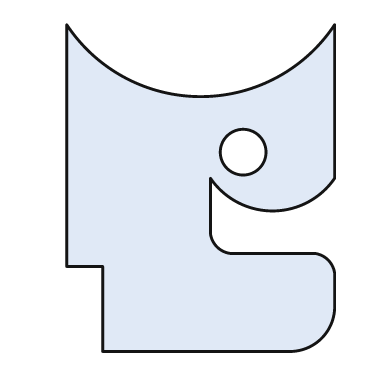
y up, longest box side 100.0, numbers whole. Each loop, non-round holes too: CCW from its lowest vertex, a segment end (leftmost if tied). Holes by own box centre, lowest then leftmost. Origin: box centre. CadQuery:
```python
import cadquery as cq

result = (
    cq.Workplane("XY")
    .moveTo(-30.0, -50.0)
    .lineTo(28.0, -50.0)
    .threePointArc((37.0, -46.0), (41.0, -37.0))
    .lineTo(41.0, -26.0)
    .threePointArc((39.0, -22.0), (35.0, -20.0))
    .lineTo(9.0, -20.0)
    .threePointArc((5.0, -18.0), (3.0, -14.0))
    .lineTo(3.0, 3.0)
    .threePointArc((22.0, -7.0), (41.0, 3.0))
    .lineTo(41.0, 50.0)
    .threePointArc((0.0, 28.0), (-41.0, 50.0))
    .lineTo(-41.0, -24.0)
    .lineTo(-30.0, -24.0)
    .close()
    .moveTo(13.0, 11.0)
    .circle(7.0)
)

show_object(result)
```